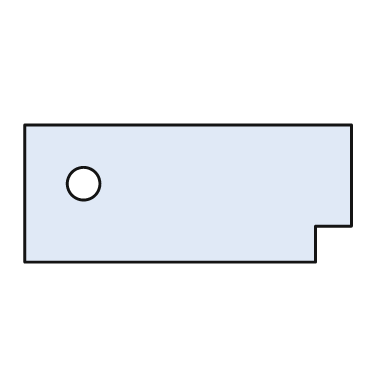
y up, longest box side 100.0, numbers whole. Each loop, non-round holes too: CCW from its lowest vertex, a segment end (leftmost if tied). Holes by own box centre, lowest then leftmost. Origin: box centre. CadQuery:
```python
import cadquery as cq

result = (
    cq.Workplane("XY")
    .moveTo(-50.0, -21.0)
    .lineTo(39.0, -21.0)
    .lineTo(39.0, -10.0)
    .lineTo(50.0, -10.0)
    .lineTo(50.0, 21.0)
    .lineTo(-50.0, 21.0)
    .close()
    .moveTo(-32.0, 3.0)
    .circle(5.0)
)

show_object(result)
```